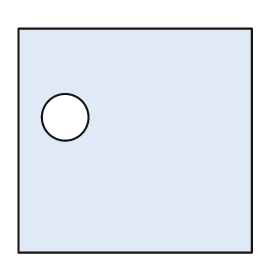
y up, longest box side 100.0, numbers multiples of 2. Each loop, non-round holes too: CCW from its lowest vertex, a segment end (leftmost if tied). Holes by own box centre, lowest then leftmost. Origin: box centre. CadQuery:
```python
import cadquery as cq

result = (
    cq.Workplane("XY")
    .moveTo(-50.0, -48.0)
    .lineTo(50.0, -48.0)
    .lineTo(50.0, 48.0)
    .lineTo(-50.0, 48.0)
    .close()
    .moveTo(-30.0, 10.0)
    .circle(10.0)
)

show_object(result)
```